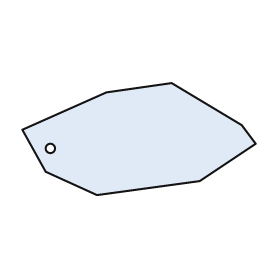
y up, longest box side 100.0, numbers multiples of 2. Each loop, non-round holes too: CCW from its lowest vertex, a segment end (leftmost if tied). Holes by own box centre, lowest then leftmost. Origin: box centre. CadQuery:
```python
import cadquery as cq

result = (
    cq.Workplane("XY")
    .moveTo(-18.0, -24.0)
    .lineTo(26.0, -18.0)
    .lineTo(50.0, -2.0)
    .lineTo(44.0, 6.0)
    .lineTo(14.0, 24.0)
    .lineTo(-14.0, 20.0)
    .lineTo(-50.0, 4.0)
    .lineTo(-40.0, -14.0)
    .close()
    .moveTo(-38.0, -4.0)
    .circle(2.0)
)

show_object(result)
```